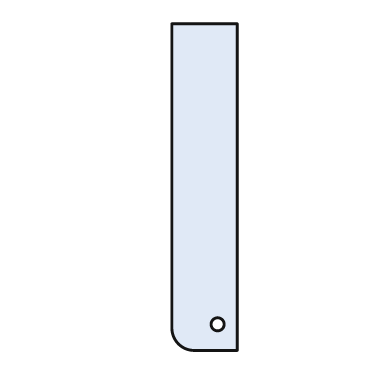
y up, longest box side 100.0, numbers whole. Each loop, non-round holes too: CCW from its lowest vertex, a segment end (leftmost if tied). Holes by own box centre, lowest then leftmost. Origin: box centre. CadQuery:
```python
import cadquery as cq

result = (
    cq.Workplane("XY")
    .moveTo(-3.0, -50.0)
    .lineTo(10.0, -50.0)
    .lineTo(10.0, 50.0)
    .lineTo(-10.0, 50.0)
    .lineTo(-10.0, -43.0)
    .threePointArc((-8.0, -48.0), (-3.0, -50.0))
    .close()
    .moveTo(4.0, -42.0)
    .circle(2.0)
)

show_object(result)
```